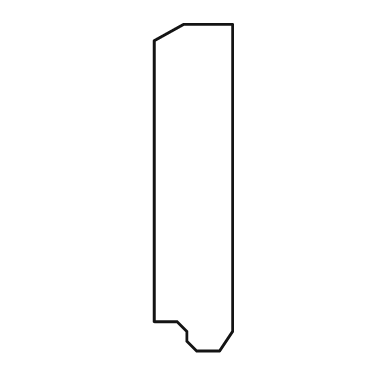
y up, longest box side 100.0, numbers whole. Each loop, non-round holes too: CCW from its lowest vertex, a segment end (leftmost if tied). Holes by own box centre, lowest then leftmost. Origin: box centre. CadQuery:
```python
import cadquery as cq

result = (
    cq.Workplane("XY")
    .moveTo(1.0, -50.0)
    .lineTo(8.0, -50.0)
    .lineTo(12.0, -44.0)
    .lineTo(12.0, 50.0)
    .lineTo(-3.0, 50.0)
    .lineTo(-12.0, 45.0)
    .lineTo(-12.0, -41.0)
    .lineTo(-5.0, -41.0)
    .lineTo(-2.0, -44.0)
    .lineTo(-2.0, -47.0)
    .close()
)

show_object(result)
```